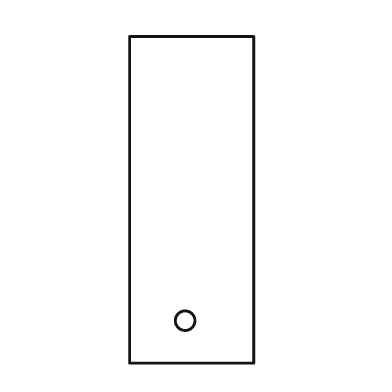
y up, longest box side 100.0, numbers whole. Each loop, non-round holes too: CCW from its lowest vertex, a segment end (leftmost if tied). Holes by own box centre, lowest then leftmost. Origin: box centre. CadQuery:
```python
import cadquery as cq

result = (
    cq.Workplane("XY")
    .moveTo(-19.0, -50.0)
    .lineTo(19.0, -50.0)
    .lineTo(19.0, 50.0)
    .lineTo(-19.0, 50.0)
    .close()
    .moveTo(-2.0, -37.0)
    .circle(3.0)
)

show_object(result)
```